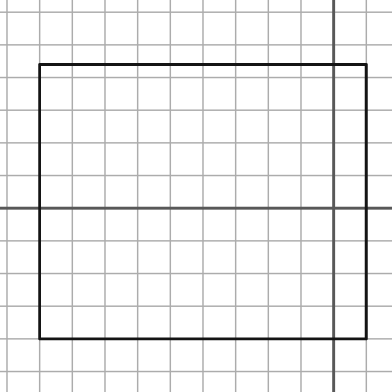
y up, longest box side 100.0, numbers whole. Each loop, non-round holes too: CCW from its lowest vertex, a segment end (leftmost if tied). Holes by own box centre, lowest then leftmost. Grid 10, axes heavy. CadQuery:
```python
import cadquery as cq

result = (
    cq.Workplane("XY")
    .moveTo(-90.0, -40.0)
    .lineTo(10.0, -40.0)
    .lineTo(10.0, 44.0)
    .lineTo(-90.0, 44.0)
    .close()
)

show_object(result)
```